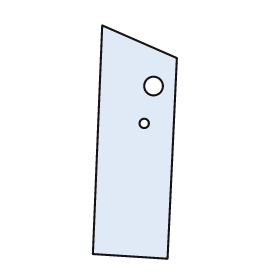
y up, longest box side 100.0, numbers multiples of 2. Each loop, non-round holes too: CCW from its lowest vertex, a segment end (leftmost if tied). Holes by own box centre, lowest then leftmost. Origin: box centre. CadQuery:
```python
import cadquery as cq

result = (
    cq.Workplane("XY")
    .moveTo(14.0, -50.0)
    .lineTo(18.0, 36.0)
    .lineTo(-14.0, 50.0)
    .lineTo(-18.0, -48.0)
    .close()
    .moveTo(4.0, 8.0)
    .circle(2.0)
    .moveTo(8.0, 24.0)
    .circle(4.0)
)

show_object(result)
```